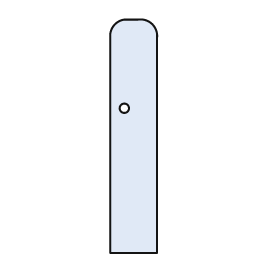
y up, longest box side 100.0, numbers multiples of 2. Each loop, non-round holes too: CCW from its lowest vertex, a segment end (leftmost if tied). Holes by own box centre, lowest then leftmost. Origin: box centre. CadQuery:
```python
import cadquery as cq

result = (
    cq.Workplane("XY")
    .moveTo(-10.0, -50.0)
    .lineTo(10.0, -50.0)
    .lineTo(10.0, 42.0)
    .threePointArc((8.0, 48.0), (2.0, 50.0))
    .lineTo(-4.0, 50.0)
    .threePointArc((-8.0, 48.0), (-10.0, 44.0))
    .close()
    .moveTo(-4.0, 12.0)
    .circle(2.0)
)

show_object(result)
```